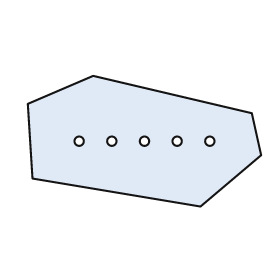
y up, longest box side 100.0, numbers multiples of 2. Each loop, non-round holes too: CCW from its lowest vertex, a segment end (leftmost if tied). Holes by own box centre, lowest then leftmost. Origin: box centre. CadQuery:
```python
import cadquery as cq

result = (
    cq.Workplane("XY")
    .moveTo(24.0, -28.0)
    .lineTo(50.0, -6.0)
    .lineTo(46.0, 12.0)
    .lineTo(-22.0, 28.0)
    .lineTo(-50.0, 16.0)
    .lineTo(-48.0, -16.0)
    .close()
    .moveTo(-28.0, 0.0)
    .circle(2.0)
    .moveTo(-14.0, 0.0)
    .circle(2.0)
    .moveTo(0.0, 0.0)
    .circle(2.0)
    .moveTo(14.0, 0.0)
    .circle(2.0)
    .moveTo(28.0, 0.0)
    .circle(2.0)
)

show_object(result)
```